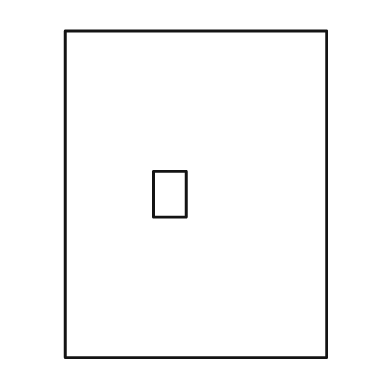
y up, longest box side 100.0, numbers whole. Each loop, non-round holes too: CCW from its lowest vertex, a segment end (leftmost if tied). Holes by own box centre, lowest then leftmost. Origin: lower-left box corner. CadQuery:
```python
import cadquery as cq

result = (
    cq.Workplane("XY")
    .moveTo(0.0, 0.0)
    .lineTo(80.0, 0.0)
    .lineTo(80.0, 100.0)
    .lineTo(0.0, 100.0)
    .close()
    .moveTo(27.0, 43.0)
    .lineTo(37.0, 43.0)
    .lineTo(37.0, 57.0)
    .lineTo(27.0, 57.0)
    .close()
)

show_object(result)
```